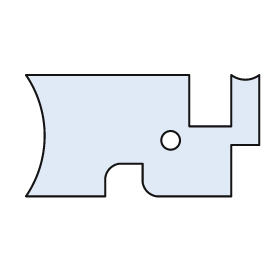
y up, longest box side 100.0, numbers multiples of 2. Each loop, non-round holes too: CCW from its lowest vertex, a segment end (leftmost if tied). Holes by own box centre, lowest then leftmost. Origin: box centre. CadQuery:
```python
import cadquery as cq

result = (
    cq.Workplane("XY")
    .moveTo(-50.0, -26.0)
    .lineTo(-16.0, -26.0)
    .lineTo(-16.0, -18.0)
    .threePointArc((-14.0, -14.0), (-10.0, -12.0))
    .lineTo(0.0, -12.0)
    .lineTo(0.0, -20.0)
    .threePointArc((2.0, -24.0), (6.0, -26.0))
    .lineTo(38.0, -26.0)
    .lineTo(38.0, -4.0)
    .lineTo(50.0, -4.0)
    .lineTo(50.0, 26.0)
    .threePointArc((44.0, 24.0), (38.0, 26.0))
    .lineTo(38.0, 4.0)
    .lineTo(20.0, 4.0)
    .lineTo(20.0, 26.0)
    .lineTo(-50.0, 26.0)
    .threePointArc((-42.0, 0.0), (-50.0, -26.0))
    .close()
    .moveTo(12.0, -2.0)
    .circle(4.0)
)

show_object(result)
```